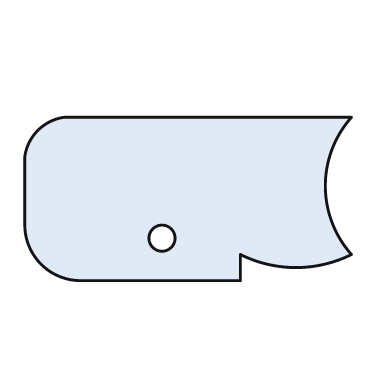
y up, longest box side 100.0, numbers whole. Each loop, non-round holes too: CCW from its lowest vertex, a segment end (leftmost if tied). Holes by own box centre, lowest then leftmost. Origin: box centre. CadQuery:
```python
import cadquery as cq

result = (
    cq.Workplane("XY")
    .moveTo(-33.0, -25.0)
    .lineTo(16.0, -25.0)
    .lineTo(16.0, -17.0)
    .threePointArc((33.0, -21.0), (50.0, -17.0))
    .threePointArc((42.0, 4.0), (50.0, 25.0))
    .lineTo(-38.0, 25.0)
    .threePointArc((-46.0, 21.0), (-50.0, 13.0))
    .lineTo(-50.0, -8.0)
    .threePointArc((-45.0, -20.0), (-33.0, -25.0))
    .close()
    .moveTo(-8.0, -12.0)
    .circle(4.0)
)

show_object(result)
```